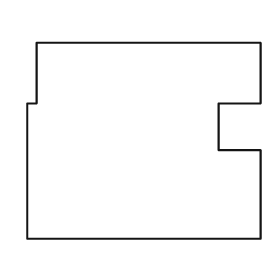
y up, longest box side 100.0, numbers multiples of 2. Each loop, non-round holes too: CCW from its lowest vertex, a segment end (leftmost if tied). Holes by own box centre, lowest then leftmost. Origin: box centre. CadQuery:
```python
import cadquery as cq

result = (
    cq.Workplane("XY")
    .moveTo(-50.0, -42.0)
    .lineTo(50.0, -42.0)
    .lineTo(50.0, -4.0)
    .lineTo(32.0, -4.0)
    .lineTo(32.0, 16.0)
    .lineTo(50.0, 16.0)
    .lineTo(50.0, 42.0)
    .lineTo(-46.0, 42.0)
    .lineTo(-46.0, 16.0)
    .lineTo(-50.0, 16.0)
    .close()
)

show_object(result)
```